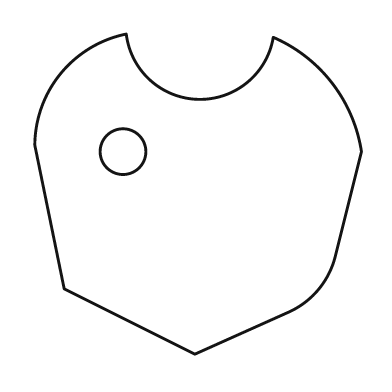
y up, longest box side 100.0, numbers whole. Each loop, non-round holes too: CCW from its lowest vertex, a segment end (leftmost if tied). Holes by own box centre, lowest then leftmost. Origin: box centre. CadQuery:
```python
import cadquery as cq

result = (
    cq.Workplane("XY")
    .moveTo(-1.0, -49.0)
    .lineTo(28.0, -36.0)
    .threePointArc((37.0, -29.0), (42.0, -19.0))
    .lineTo(50.0, 13.0)
    .threePointArc((41.0, 34.0), (23.0, 48.0))
    .threePointArc((0.0, 29.0), (-22.0, 49.0))
    .threePointArc((-42.0, 37.0), (-50.0, 15.0))
    .lineTo(-41.0, -29.0)
    .close()
    .moveTo(-23.0, 13.0)
    .circle(7.0)
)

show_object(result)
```